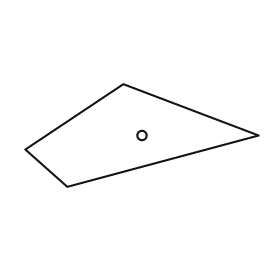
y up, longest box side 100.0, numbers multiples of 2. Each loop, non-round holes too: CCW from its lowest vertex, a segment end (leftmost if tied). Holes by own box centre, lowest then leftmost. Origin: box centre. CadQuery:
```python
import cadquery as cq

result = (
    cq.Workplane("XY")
    .moveTo(-32.0, -22.0)
    .lineTo(50.0, 0.0)
    .lineTo(-8.0, 22.0)
    .lineTo(-50.0, -6.0)
    .close()
    .moveTo(0.0, 0.0)
    .circle(2.0)
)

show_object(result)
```